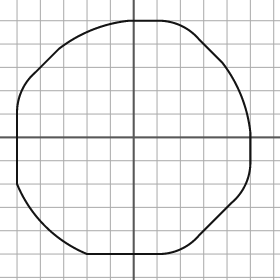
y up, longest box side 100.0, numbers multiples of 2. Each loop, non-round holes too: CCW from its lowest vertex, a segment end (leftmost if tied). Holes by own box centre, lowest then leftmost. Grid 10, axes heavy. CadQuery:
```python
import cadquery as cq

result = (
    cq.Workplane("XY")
    .moveTo(-20.0, -50.0)
    .lineTo(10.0, -50.0)
    .threePointArc((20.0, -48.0), (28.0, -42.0))
    .lineTo(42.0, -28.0)
    .threePointArc((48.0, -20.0), (50.0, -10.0))
    .lineTo(50.0, 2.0)
    .threePointArc((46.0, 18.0), (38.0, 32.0))
    .lineTo(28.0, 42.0)
    .threePointArc((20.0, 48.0), (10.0, 50.0))
    .lineTo(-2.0, 50.0)
    .threePointArc((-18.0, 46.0), (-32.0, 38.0))
    .lineTo(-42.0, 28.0)
    .threePointArc((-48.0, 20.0), (-50.0, 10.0))
    .lineTo(-50.0, -20.0)
    .threePointArc((-38.0, -38.0), (-20.0, -50.0))
    .close()
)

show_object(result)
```